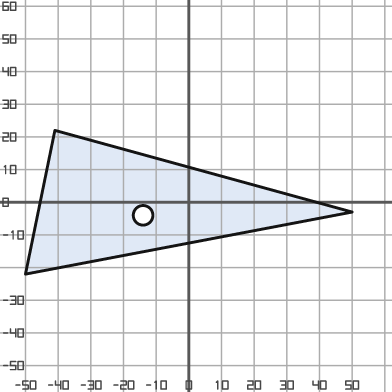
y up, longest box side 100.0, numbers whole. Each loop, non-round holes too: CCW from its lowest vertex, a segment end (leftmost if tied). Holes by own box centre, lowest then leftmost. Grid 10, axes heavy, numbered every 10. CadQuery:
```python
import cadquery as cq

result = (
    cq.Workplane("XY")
    .moveTo(-50.0, -22.0)
    .lineTo(50.0, -3.0)
    .lineTo(-41.0, 22.0)
    .close()
    .moveTo(-14.0, -4.0)
    .circle(3.0)
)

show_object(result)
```